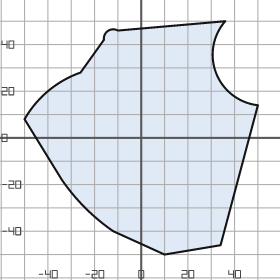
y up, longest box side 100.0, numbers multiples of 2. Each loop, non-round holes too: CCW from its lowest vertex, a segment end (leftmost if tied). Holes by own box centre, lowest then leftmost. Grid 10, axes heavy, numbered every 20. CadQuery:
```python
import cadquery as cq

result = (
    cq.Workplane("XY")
    .moveTo(10.0, -50.0)
    .lineTo(34.0, -46.0)
    .lineTo(50.0, 14.0)
    .threePointArc((32.0, 28.0), (36.0, 50.0))
    .lineTo(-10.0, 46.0)
    .threePointArc((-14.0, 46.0), (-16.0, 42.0))
    .lineTo(-26.0, 28.0)
    .threePointArc((-40.0, 20.0), (-50.0, 8.0))
    .lineTo(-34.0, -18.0)
    .threePointArc((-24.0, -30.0), (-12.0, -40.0))
    .close()
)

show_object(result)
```